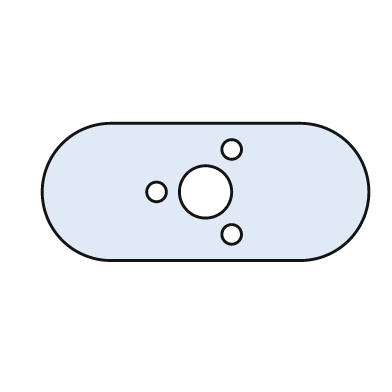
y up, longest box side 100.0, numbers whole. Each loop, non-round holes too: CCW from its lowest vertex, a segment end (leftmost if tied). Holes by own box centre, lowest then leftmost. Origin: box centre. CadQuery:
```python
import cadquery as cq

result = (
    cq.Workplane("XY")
    .moveTo(-29.0, -21.0)
    .lineTo(29.0, -21.0)
    .threePointArc((50.0, 0.0), (29.0, 21.0))
    .lineTo(-29.0, 21.0)
    .threePointArc((-50.0, 0.0), (-29.0, -21.0))
    .close()
    .moveTo(8.0, -13.0)
    .circle(3.0)
    .moveTo(-15.0, 0.0)
    .circle(3.0)
    .moveTo(0.0, 0.0)
    .circle(8.0)
    .moveTo(8.0, 13.0)
    .circle(3.0)
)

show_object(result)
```